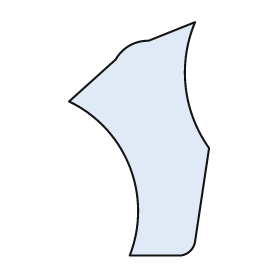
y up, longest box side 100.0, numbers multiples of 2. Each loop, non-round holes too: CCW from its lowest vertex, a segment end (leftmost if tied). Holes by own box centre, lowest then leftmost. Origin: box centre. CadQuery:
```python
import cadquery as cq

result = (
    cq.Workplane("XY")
    .moveTo(-4.0, -50.0)
    .lineTo(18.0, -50.0)
    .threePointArc((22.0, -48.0), (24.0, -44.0))
    .lineTo(30.0, -4.0)
    .threePointArc((20.0, 22.0), (24.0, 50.0))
    .lineTo(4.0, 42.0)
    .threePointArc((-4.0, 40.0), (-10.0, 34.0))
    .lineTo(-30.0, 16.0)
    .threePointArc((-4.0, -12.0), (-4.0, -50.0))
    .close()
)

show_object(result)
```